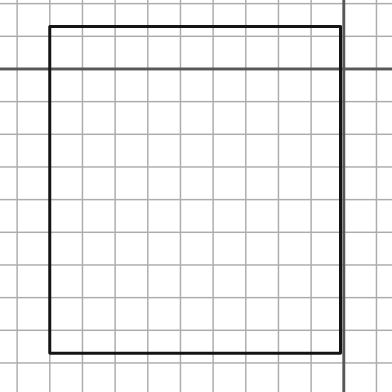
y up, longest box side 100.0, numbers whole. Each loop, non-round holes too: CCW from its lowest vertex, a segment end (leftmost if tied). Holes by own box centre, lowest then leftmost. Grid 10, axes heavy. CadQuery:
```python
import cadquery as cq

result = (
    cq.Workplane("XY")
    .moveTo(-90.0, -87.0)
    .lineTo(-1.0, -87.0)
    .lineTo(-1.0, 13.0)
    .lineTo(-90.0, 13.0)
    .close()
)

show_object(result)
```